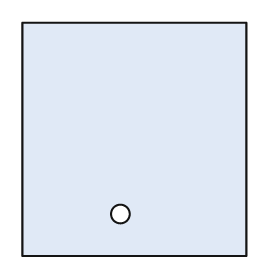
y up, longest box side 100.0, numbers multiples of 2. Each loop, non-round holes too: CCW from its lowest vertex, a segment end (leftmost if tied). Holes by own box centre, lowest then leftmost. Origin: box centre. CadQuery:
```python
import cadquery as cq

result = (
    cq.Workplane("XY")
    .moveTo(-48.0, -50.0)
    .lineTo(48.0, -50.0)
    .lineTo(48.0, 50.0)
    .lineTo(-48.0, 50.0)
    .close()
    .moveTo(-6.0, -32.0)
    .circle(4.0)
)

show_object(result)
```